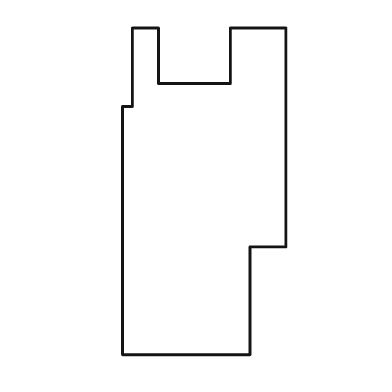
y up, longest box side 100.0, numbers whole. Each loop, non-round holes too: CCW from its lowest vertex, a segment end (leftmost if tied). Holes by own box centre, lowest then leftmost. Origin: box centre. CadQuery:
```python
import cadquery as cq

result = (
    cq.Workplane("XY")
    .moveTo(-25.0, -50.0)
    .lineTo(14.0, -50.0)
    .lineTo(14.0, -17.0)
    .lineTo(25.0, -17.0)
    .lineTo(25.0, 50.0)
    .lineTo(8.0, 50.0)
    .lineTo(8.0, 33.0)
    .lineTo(-14.0, 33.0)
    .lineTo(-14.0, 50.0)
    .lineTo(-22.0, 50.0)
    .lineTo(-22.0, 26.0)
    .lineTo(-25.0, 26.0)
    .close()
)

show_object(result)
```